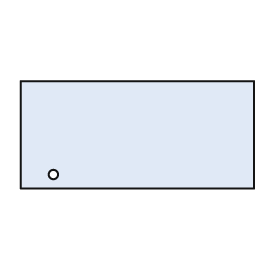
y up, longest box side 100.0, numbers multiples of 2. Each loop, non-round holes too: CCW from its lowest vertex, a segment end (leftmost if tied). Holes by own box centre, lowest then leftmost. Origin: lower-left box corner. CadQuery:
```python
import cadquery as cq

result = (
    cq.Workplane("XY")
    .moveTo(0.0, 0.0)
    .lineTo(100.0, 0.0)
    .lineTo(100.0, 46.0)
    .lineTo(0.0, 46.0)
    .close()
    .moveTo(14.0, 6.0)
    .circle(2.0)
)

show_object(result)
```